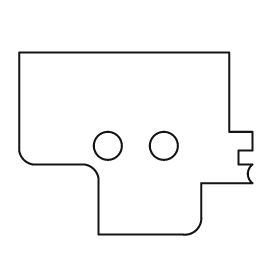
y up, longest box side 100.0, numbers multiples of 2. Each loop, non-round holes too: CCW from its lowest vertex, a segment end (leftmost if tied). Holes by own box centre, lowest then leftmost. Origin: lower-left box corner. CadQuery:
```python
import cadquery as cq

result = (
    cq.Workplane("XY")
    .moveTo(34.0, 0.0)
    .lineTo(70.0, 0.0)
    .threePointArc((76.0, 2.0), (78.0, 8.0))
    .lineTo(78.0, 22.0)
    .lineTo(100.0, 22.0)
    .threePointArc((98.0, 26.0), (100.0, 30.0))
    .lineTo(94.0, 30.0)
    .lineTo(94.0, 36.0)
    .lineTo(100.0, 36.0)
    .lineTo(100.0, 44.0)
    .lineTo(90.0, 44.0)
    .lineTo(90.0, 78.0)
    .lineTo(0.0, 78.0)
    .lineTo(0.0, 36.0)
    .threePointArc((2.0, 32.0), (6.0, 30.0))
    .lineTo(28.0, 30.0)
    .threePointArc((32.0, 28.0), (34.0, 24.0))
    .close()
    .moveTo(38.0, 38.0)
    .circle(6.0)
    .moveTo(62.0, 38.0)
    .circle(6.0)
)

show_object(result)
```